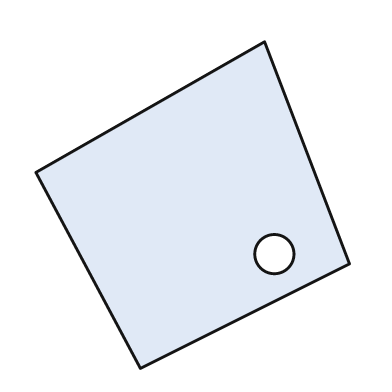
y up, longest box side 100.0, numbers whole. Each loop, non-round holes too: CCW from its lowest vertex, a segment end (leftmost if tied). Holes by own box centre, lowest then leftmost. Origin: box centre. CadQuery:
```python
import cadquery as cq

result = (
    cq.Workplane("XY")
    .moveTo(-16.0, -50.0)
    .lineTo(48.0, -18.0)
    .lineTo(22.0, 50.0)
    .lineTo(-48.0, 10.0)
    .close()
    .moveTo(25.0, -15.0)
    .circle(6.0)
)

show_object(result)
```